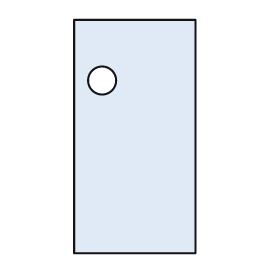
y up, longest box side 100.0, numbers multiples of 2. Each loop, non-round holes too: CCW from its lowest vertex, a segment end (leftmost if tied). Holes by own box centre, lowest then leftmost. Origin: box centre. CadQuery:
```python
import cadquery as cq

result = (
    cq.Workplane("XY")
    .moveTo(-26.0, -50.0)
    .lineTo(26.0, -50.0)
    .lineTo(26.0, 50.0)
    .lineTo(-26.0, 50.0)
    .close()
    .moveTo(-14.0, 24.0)
    .circle(6.0)
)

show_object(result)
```